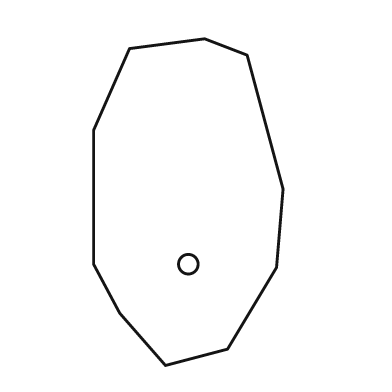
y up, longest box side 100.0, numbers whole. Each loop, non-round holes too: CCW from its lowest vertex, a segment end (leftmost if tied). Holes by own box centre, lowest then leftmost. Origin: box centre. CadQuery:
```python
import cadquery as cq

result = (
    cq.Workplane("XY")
    .moveTo(-7.0, -50.0)
    .lineTo(12.0, -45.0)
    .lineTo(27.0, -20.0)
    .lineTo(29.0, 4.0)
    .lineTo(18.0, 45.0)
    .lineTo(5.0, 50.0)
    .lineTo(-18.0, 47.0)
    .lineTo(-29.0, 22.0)
    .lineTo(-29.0, -19.0)
    .lineTo(-21.0, -34.0)
    .close()
    .moveTo(0.0, -19.0)
    .circle(3.0)
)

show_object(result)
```